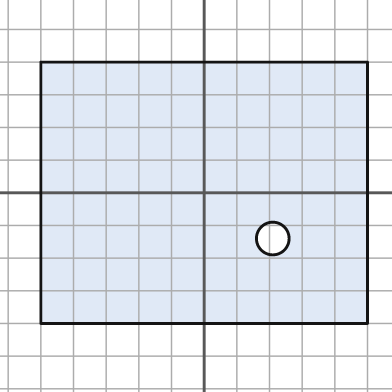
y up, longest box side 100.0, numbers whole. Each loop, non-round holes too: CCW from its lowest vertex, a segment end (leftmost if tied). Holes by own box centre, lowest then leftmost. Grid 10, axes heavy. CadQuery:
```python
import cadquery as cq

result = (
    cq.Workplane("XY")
    .moveTo(-50.0, -40.0)
    .lineTo(50.0, -40.0)
    .lineTo(50.0, 40.0)
    .lineTo(-50.0, 40.0)
    .close()
    .moveTo(21.0, -14.0)
    .circle(5.0)
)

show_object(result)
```